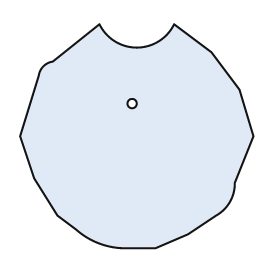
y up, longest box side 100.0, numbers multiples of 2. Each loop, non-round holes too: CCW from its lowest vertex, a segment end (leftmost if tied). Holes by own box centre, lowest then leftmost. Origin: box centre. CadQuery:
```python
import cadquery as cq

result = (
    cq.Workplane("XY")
    .moveTo(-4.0, -48.0)
    .lineTo(8.0, -48.0)
    .lineTo(22.0, -42.0)
    .lineTo(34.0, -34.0)
    .threePointArc((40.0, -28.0), (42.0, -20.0))
    .lineTo(50.0, 0.0)
    .lineTo(44.0, 20.0)
    .lineTo(32.0, 36.0)
    .lineTo(16.0, 48.0)
    .threePointArc((0.0, 38.0), (-16.0, 48.0))
    .lineTo(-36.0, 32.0)
    .threePointArc((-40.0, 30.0), (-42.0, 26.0))
    .lineTo(-50.0, 0.0)
    .lineTo(-44.0, -18.0)
    .lineTo(-34.0, -34.0)
    .lineTo(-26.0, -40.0)
    .threePointArc((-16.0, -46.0), (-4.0, -48.0))
    .close()
    .moveTo(-2.0, 14.0)
    .circle(2.0)
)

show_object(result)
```